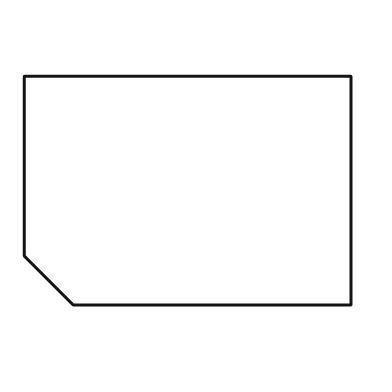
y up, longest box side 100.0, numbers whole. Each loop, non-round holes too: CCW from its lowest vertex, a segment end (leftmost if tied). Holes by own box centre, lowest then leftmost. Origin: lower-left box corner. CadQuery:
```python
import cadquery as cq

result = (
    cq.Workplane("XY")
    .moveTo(15.0, 0.0)
    .lineTo(100.0, 0.0)
    .lineTo(100.0, 70.0)
    .lineTo(0.0, 70.0)
    .lineTo(0.0, 15.0)
    .close()
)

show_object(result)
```